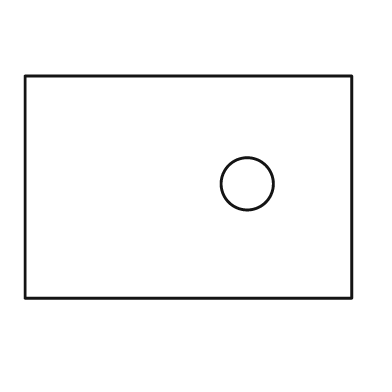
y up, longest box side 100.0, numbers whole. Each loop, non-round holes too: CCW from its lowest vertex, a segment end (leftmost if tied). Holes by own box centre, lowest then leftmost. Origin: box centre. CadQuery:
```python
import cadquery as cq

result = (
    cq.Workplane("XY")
    .moveTo(-50.0, -34.0)
    .lineTo(50.0, -34.0)
    .lineTo(50.0, 34.0)
    .lineTo(-50.0, 34.0)
    .close()
    .moveTo(18.0, 1.0)
    .circle(8.0)
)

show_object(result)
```